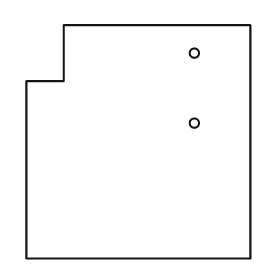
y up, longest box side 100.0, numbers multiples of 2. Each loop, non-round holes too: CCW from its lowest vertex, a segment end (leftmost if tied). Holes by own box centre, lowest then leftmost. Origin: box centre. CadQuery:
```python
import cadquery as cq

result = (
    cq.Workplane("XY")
    .moveTo(-48.0, -50.0)
    .lineTo(48.0, -50.0)
    .lineTo(48.0, 50.0)
    .lineTo(-32.0, 50.0)
    .lineTo(-32.0, 26.0)
    .lineTo(-48.0, 26.0)
    .close()
    .moveTo(24.0, 8.0)
    .circle(2.0)
    .moveTo(24.0, 38.0)
    .circle(2.0)
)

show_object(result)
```